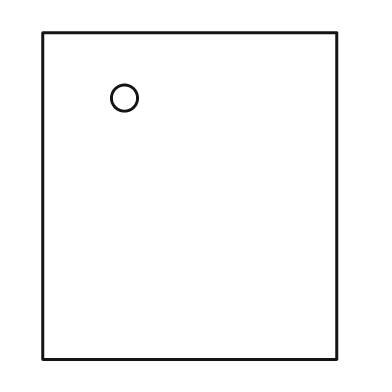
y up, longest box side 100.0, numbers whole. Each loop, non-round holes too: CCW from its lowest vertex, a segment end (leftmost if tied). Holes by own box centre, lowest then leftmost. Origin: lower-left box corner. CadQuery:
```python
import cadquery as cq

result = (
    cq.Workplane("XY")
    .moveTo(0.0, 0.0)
    .lineTo(90.0, 0.0)
    .lineTo(90.0, 100.0)
    .lineTo(0.0, 100.0)
    .close()
    .moveTo(25.0, 80.0)
    .circle(4.0)
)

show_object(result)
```